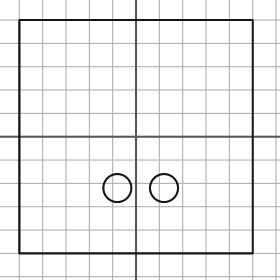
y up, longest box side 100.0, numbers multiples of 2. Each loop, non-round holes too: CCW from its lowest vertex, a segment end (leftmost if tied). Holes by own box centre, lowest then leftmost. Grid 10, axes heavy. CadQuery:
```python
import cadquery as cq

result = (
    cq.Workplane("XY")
    .moveTo(-50.0, -50.0)
    .lineTo(50.0, -50.0)
    .lineTo(50.0, 50.0)
    .lineTo(-50.0, 50.0)
    .close()
    .moveTo(-8.0, -22.0)
    .circle(6.0)
    .moveTo(12.0, -22.0)
    .circle(6.0)
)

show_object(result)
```